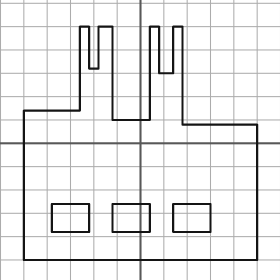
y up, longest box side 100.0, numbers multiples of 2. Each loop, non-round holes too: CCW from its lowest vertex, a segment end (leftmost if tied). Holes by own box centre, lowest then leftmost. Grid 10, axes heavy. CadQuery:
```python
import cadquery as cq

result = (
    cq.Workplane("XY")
    .moveTo(-50.0, -50.0)
    .lineTo(50.0, -50.0)
    .lineTo(50.0, 8.0)
    .lineTo(18.0, 8.0)
    .lineTo(18.0, 50.0)
    .lineTo(14.0, 50.0)
    .lineTo(14.0, 30.0)
    .lineTo(8.0, 30.0)
    .lineTo(8.0, 50.0)
    .lineTo(4.0, 50.0)
    .lineTo(4.0, 10.0)
    .lineTo(-12.0, 10.0)
    .lineTo(-12.0, 50.0)
    .lineTo(-18.0, 50.0)
    .lineTo(-18.0, 32.0)
    .lineTo(-22.0, 32.0)
    .lineTo(-22.0, 50.0)
    .lineTo(-26.0, 50.0)
    .lineTo(-26.0, 14.0)
    .lineTo(-50.0, 14.0)
    .close()
    .moveTo(-38.0, -38.0)
    .lineTo(-22.0, -38.0)
    .lineTo(-22.0, -26.0)
    .lineTo(-38.0, -26.0)
    .close()
    .moveTo(-12.0, -38.0)
    .lineTo(4.0, -38.0)
    .lineTo(4.0, -26.0)
    .lineTo(-12.0, -26.0)
    .close()
    .moveTo(14.0, -38.0)
    .lineTo(30.0, -38.0)
    .lineTo(30.0, -26.0)
    .lineTo(14.0, -26.0)
    .close()
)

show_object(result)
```